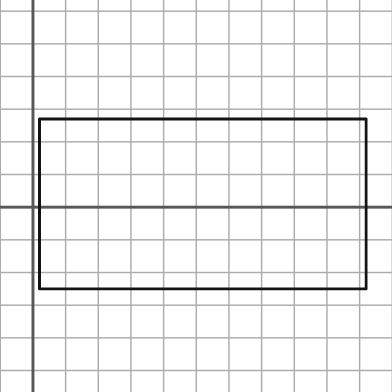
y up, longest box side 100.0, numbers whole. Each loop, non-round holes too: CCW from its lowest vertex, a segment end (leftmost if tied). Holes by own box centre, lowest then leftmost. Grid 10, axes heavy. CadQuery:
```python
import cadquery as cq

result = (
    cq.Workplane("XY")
    .moveTo(2.0, -25.0)
    .lineTo(102.0, -25.0)
    .lineTo(102.0, 27.0)
    .lineTo(2.0, 27.0)
    .close()
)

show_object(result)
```